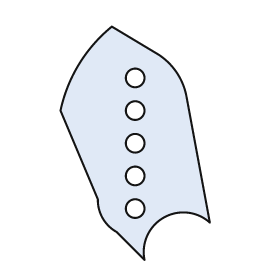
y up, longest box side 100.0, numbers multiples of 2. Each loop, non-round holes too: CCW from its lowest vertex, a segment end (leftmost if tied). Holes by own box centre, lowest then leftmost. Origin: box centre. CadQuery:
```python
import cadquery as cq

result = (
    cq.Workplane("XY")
    .moveTo(4.0, -50.0)
    .threePointArc((12.0, -32.0), (32.0, -34.0))
    .lineTo(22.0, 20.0)
    .threePointArc((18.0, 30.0), (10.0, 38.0))
    .lineTo(-10.0, 50.0)
    .threePointArc((-24.0, 34.0), (-32.0, 14.0))
    .lineTo(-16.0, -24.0)
    .threePointArc((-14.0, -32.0), (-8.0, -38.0))
    .close()
    .moveTo(0.0, -28.0)
    .circle(4.0)
    .moveTo(0.0, -14.0)
    .circle(4.0)
    .moveTo(0.0, 0.0)
    .circle(4.0)
    .moveTo(0.0, 14.0)
    .circle(4.0)
    .moveTo(0.0, 28.0)
    .circle(4.0)
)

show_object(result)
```